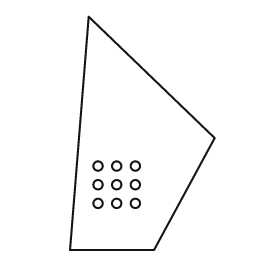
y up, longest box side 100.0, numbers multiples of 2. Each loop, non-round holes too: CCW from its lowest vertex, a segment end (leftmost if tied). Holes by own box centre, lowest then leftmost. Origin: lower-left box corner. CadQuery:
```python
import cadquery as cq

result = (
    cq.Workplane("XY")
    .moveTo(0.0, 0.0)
    .lineTo(36.0, 0.0)
    .lineTo(62.0, 48.0)
    .lineTo(8.0, 100.0)
    .close()
    .moveTo(12.0, 20.0)
    .circle(2.0)
    .moveTo(20.0, 20.0)
    .circle(2.0)
    .moveTo(28.0, 20.0)
    .circle(2.0)
    .moveTo(12.0, 28.0)
    .circle(2.0)
    .moveTo(20.0, 28.0)
    .circle(2.0)
    .moveTo(28.0, 28.0)
    .circle(2.0)
    .moveTo(12.0, 36.0)
    .circle(2.0)
    .moveTo(20.0, 36.0)
    .circle(2.0)
    .moveTo(28.0, 36.0)
    .circle(2.0)
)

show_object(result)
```